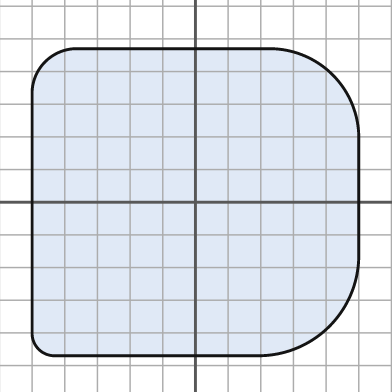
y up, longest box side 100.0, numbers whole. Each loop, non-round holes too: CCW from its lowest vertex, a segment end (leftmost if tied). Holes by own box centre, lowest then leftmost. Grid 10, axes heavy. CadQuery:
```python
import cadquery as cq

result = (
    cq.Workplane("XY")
    .moveTo(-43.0, -47.0)
    .lineTo(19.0, -47.0)
    .threePointArc((41.0, -38.0), (50.0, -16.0))
    .lineTo(50.0, 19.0)
    .threePointArc((42.0, 39.0), (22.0, 47.0))
    .lineTo(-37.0, 47.0)
    .threePointArc((-46.0, 43.0), (-50.0, 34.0))
    .lineTo(-50.0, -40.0)
    .threePointArc((-48.0, -45.0), (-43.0, -47.0))
    .close()
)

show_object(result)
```